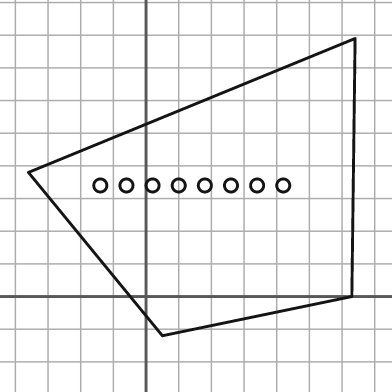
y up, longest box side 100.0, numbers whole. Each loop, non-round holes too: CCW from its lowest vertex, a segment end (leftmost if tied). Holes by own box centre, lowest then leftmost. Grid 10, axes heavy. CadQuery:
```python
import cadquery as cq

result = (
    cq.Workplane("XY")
    .moveTo(5.0, -12.0)
    .lineTo(63.0, 0.0)
    .lineTo(64.0, 79.0)
    .lineTo(-36.0, 38.0)
    .close()
    .moveTo(-14.0, 34.0)
    .circle(2.0)
    .moveTo(-6.0, 34.0)
    .circle(2.0)
    .moveTo(2.0, 34.0)
    .circle(2.0)
    .moveTo(10.0, 34.0)
    .circle(2.0)
    .moveTo(18.0, 34.0)
    .circle(2.0)
    .moveTo(26.0, 34.0)
    .circle(2.0)
    .moveTo(34.0, 34.0)
    .circle(2.0)
    .moveTo(42.0, 34.0)
    .circle(2.0)
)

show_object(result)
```